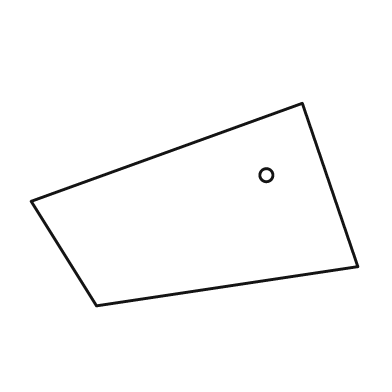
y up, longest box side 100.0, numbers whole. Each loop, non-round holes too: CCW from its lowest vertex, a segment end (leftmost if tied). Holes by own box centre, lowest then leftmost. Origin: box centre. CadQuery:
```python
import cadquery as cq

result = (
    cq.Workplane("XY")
    .moveTo(-30.0, -31.0)
    .lineTo(50.0, -19.0)
    .lineTo(33.0, 31.0)
    .lineTo(-50.0, 1.0)
    .close()
    .moveTo(22.0, 9.0)
    .circle(2.0)
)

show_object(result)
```